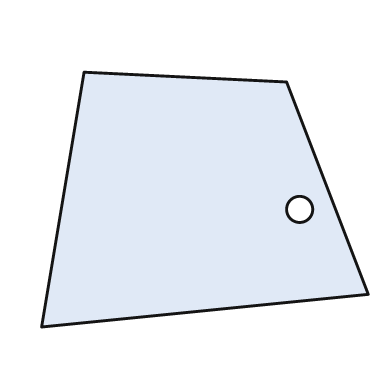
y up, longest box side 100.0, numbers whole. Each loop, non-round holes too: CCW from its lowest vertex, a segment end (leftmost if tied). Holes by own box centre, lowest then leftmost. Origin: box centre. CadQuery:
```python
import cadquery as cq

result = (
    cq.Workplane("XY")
    .moveTo(-50.0, -39.0)
    .lineTo(50.0, -29.0)
    .lineTo(25.0, 36.0)
    .lineTo(-37.0, 39.0)
    .close()
    .moveTo(29.0, -3.0)
    .circle(4.0)
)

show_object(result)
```